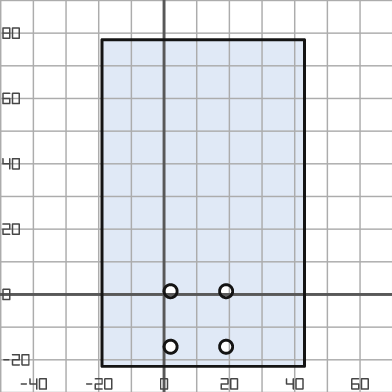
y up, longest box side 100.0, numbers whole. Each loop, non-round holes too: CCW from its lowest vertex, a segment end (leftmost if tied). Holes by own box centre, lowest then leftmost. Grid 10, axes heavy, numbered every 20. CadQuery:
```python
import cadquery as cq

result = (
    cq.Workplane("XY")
    .moveTo(-19.0, -22.0)
    .lineTo(43.0, -22.0)
    .lineTo(43.0, 78.0)
    .lineTo(-19.0, 78.0)
    .close()
    .moveTo(2.0, -16.0)
    .circle(2.0)
    .moveTo(19.0, -16.0)
    .circle(2.0)
    .moveTo(2.0, 1.0)
    .circle(2.0)
    .moveTo(19.0, 1.0)
    .circle(2.0)
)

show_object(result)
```